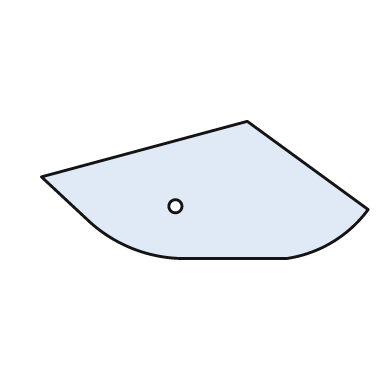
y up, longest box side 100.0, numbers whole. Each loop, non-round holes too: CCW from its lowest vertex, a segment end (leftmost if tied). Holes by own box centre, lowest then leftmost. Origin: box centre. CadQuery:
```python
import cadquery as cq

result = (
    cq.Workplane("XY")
    .moveTo(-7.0, -21.0)
    .lineTo(25.0, -21.0)
    .threePointArc((39.0, -16.0), (50.0, -6.0))
    .lineTo(13.0, 21.0)
    .lineTo(-50.0, 4.0)
    .lineTo(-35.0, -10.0)
    .threePointArc((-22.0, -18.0), (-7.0, -21.0))
    .close()
    .moveTo(-9.0, -5.0)
    .circle(2.0)
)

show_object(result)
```